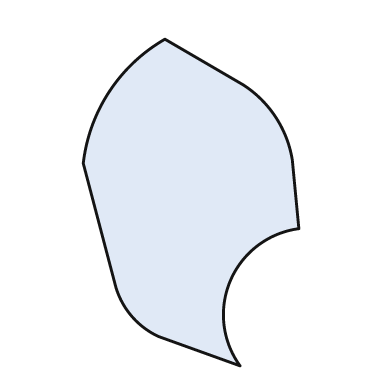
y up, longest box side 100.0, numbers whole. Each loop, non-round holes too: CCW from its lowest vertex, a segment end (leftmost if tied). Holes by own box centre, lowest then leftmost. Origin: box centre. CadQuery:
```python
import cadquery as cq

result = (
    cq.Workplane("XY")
    .moveTo(15.0, -50.0)
    .threePointArc((12.0, -24.0), (33.0, -8.0))
    .lineTo(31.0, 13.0)
    .threePointArc((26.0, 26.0), (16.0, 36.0))
    .lineTo(-8.0, 50.0)
    .threePointArc((-25.0, 34.0), (-33.0, 12.0))
    .lineTo(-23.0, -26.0)
    .threePointArc((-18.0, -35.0), (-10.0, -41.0))
    .close()
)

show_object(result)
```